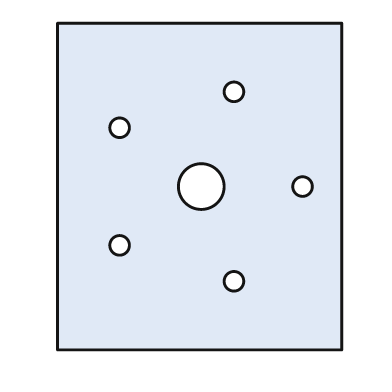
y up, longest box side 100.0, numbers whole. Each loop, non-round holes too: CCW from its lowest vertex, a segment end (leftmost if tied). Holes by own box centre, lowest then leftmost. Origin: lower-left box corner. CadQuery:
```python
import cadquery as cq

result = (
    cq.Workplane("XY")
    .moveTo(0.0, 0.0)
    .lineTo(87.0, 0.0)
    .lineTo(87.0, 100.0)
    .lineTo(0.0, 100.0)
    .close()
    .moveTo(54.0, 21.0)
    .circle(3.0)
    .moveTo(19.0, 32.0)
    .circle(3.0)
    .moveTo(44.0, 50.0)
    .circle(7.0)
    .moveTo(75.0, 50.0)
    .circle(3.0)
    .moveTo(19.0, 68.0)
    .circle(3.0)
    .moveTo(54.0, 79.0)
    .circle(3.0)
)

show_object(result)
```